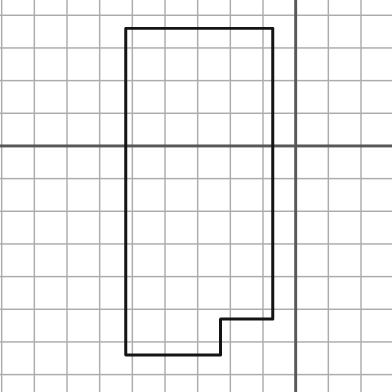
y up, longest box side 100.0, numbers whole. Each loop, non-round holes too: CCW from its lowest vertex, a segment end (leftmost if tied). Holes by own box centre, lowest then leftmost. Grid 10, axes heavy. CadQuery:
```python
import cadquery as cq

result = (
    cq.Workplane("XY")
    .moveTo(-52.0, -64.0)
    .lineTo(-23.0, -64.0)
    .lineTo(-23.0, -53.0)
    .lineTo(-7.0, -53.0)
    .lineTo(-7.0, 36.0)
    .lineTo(-52.0, 36.0)
    .close()
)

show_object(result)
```